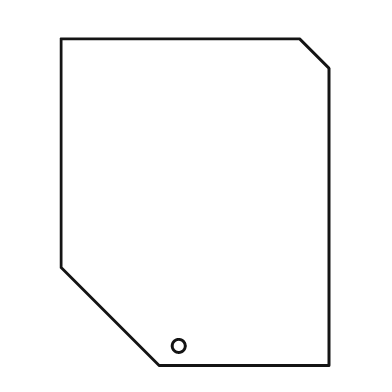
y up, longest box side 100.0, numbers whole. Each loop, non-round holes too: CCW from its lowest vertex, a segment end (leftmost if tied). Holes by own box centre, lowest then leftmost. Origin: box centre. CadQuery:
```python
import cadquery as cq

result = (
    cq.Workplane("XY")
    .moveTo(-11.0, -50.0)
    .lineTo(41.0, -50.0)
    .lineTo(41.0, 41.0)
    .lineTo(32.0, 50.0)
    .lineTo(-41.0, 50.0)
    .lineTo(-41.0, -20.0)
    .close()
    .moveTo(-5.0, -44.0)
    .circle(2.0)
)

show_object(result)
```